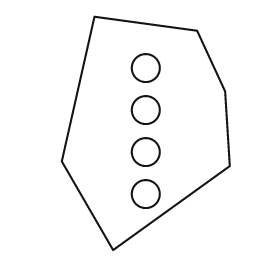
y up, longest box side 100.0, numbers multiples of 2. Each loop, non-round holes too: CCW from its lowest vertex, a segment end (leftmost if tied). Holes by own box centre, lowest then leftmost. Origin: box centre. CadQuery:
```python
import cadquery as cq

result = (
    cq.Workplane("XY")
    .moveTo(-14.0, -50.0)
    .lineTo(36.0, -14.0)
    .lineTo(34.0, 18.0)
    .lineTo(22.0, 44.0)
    .lineTo(-22.0, 50.0)
    .lineTo(-36.0, -12.0)
    .close()
    .moveTo(0.0, -26.0)
    .circle(6.0)
    .moveTo(0.0, -8.0)
    .circle(6.0)
    .moveTo(0.0, 10.0)
    .circle(6.0)
    .moveTo(0.0, 28.0)
    .circle(6.0)
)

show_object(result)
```